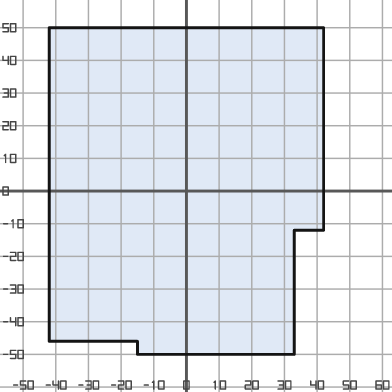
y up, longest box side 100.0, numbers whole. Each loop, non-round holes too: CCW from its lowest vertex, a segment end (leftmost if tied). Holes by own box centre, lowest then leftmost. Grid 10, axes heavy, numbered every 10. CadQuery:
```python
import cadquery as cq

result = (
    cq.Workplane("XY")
    .moveTo(-15.0, -50.0)
    .lineTo(33.0, -50.0)
    .lineTo(33.0, -12.0)
    .lineTo(42.0, -12.0)
    .lineTo(42.0, 50.0)
    .lineTo(-42.0, 50.0)
    .lineTo(-42.0, -46.0)
    .lineTo(-15.0, -46.0)
    .close()
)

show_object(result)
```